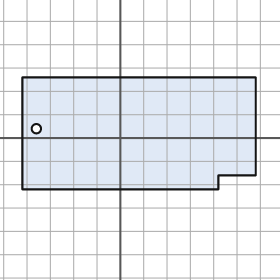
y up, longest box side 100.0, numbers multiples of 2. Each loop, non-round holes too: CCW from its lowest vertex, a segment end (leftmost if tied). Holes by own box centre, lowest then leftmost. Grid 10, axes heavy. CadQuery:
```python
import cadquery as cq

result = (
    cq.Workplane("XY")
    .moveTo(-42.0, -22.0)
    .lineTo(42.0, -22.0)
    .lineTo(42.0, -16.0)
    .lineTo(58.0, -16.0)
    .lineTo(58.0, 26.0)
    .lineTo(-42.0, 26.0)
    .close()
    .moveTo(-36.0, 4.0)
    .circle(2.0)
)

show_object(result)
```